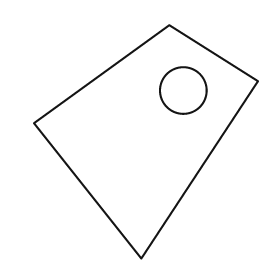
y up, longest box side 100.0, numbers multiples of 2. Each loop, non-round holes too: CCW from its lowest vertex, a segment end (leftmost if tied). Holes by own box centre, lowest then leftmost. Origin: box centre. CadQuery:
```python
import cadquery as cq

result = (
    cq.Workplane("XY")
    .moveTo(-2.0, -50.0)
    .lineTo(48.0, 26.0)
    .lineTo(10.0, 50.0)
    .lineTo(-48.0, 8.0)
    .close()
    .moveTo(16.0, 22.0)
    .circle(10.0)
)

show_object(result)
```